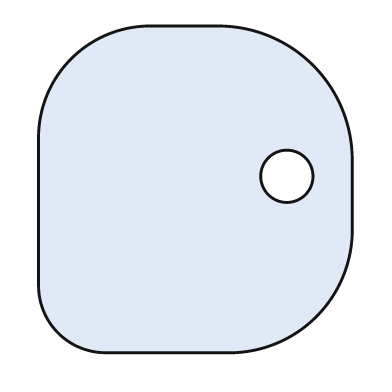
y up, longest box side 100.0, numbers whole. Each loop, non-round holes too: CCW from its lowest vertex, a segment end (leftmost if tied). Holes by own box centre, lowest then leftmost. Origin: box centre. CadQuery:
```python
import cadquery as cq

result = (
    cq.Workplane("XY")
    .moveTo(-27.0, -50.0)
    .lineTo(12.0, -50.0)
    .threePointArc((37.0, -39.0), (48.0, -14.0))
    .lineTo(48.0, 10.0)
    .threePointArc((36.0, 38.0), (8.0, 50.0))
    .lineTo(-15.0, 50.0)
    .threePointArc((-38.0, 40.0), (-48.0, 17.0))
    .lineTo(-48.0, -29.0)
    .threePointArc((-42.0, -44.0), (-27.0, -50.0))
    .close()
    .moveTo(28.0, 4.0)
    .circle(8.0)
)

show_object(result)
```